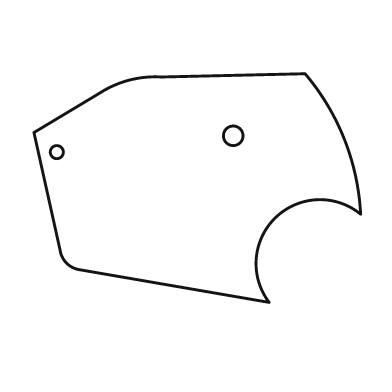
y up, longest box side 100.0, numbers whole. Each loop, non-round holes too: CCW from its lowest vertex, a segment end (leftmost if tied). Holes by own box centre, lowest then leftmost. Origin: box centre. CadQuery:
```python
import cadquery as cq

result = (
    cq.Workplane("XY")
    .moveTo(22.0, -35.0)
    .threePointArc((24.0, -9.0), (50.0, -8.0))
    .threePointArc((45.0, 15.0), (33.0, 35.0))
    .lineTo(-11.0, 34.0)
    .threePointArc((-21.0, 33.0), (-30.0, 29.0))
    .lineTo(-50.0, 17.0)
    .lineTo(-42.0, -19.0)
    .threePointArc((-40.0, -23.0), (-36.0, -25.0))
    .close()
    .moveTo(-43.0, 11.0)
    .circle(2.0)
    .moveTo(11.0, 16.0)
    .circle(3.0)
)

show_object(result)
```